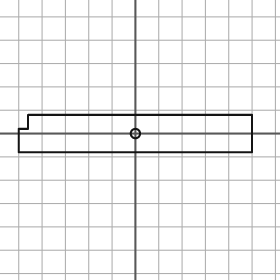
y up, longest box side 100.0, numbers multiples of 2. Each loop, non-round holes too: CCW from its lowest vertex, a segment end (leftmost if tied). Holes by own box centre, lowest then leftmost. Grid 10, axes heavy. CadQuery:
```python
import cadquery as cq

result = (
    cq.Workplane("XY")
    .moveTo(-50.0, -8.0)
    .lineTo(50.0, -8.0)
    .lineTo(50.0, 8.0)
    .lineTo(-46.0, 8.0)
    .lineTo(-46.0, 2.0)
    .lineTo(-50.0, 2.0)
    .close()
    .moveTo(0.0, 0.0)
    .circle(2.0)
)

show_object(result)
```